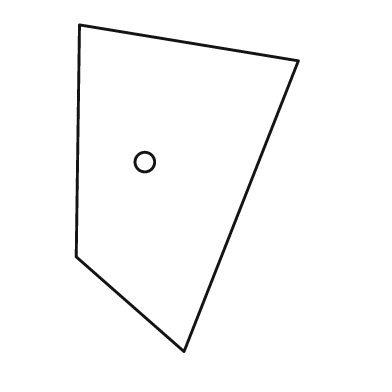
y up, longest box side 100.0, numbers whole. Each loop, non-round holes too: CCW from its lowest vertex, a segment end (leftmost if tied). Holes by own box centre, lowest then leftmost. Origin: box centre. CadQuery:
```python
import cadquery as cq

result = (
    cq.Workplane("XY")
    .moveTo(-1.0, -50.0)
    .lineTo(34.0, 39.0)
    .lineTo(-33.0, 50.0)
    .lineTo(-34.0, -21.0)
    .close()
    .moveTo(-13.0, 8.0)
    .circle(3.0)
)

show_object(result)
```